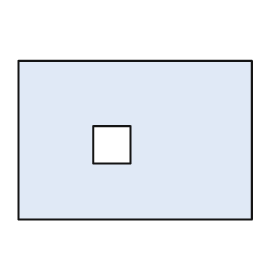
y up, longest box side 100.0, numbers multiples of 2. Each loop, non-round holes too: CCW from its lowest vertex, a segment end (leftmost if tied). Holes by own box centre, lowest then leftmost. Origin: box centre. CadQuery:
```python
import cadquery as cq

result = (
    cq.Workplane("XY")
    .moveTo(-50.0, -34.0)
    .lineTo(50.0, -34.0)
    .lineTo(50.0, 34.0)
    .lineTo(-50.0, 34.0)
    .close()
    .moveTo(-18.0, -10.0)
    .lineTo(-2.0, -10.0)
    .lineTo(-2.0, 6.0)
    .lineTo(-18.0, 6.0)
    .close()
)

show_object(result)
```